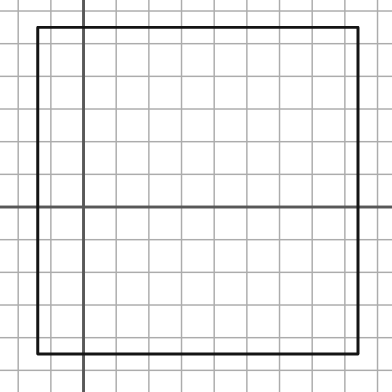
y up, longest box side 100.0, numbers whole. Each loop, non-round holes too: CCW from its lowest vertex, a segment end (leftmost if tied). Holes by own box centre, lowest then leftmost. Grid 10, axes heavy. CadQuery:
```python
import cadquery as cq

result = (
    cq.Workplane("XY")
    .moveTo(-14.0, -45.0)
    .lineTo(84.0, -45.0)
    .lineTo(84.0, 55.0)
    .lineTo(-14.0, 55.0)
    .close()
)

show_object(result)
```